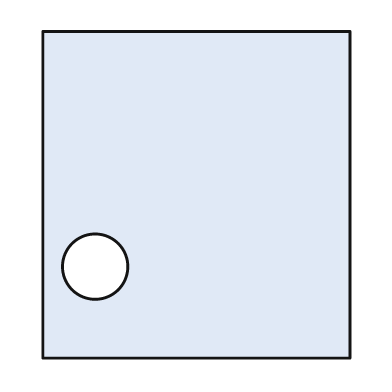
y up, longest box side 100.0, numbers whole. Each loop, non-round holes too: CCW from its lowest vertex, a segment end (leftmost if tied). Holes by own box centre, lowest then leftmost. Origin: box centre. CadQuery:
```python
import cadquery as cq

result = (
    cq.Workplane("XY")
    .moveTo(-47.0, -50.0)
    .lineTo(47.0, -50.0)
    .lineTo(47.0, 50.0)
    .lineTo(-47.0, 50.0)
    .close()
    .moveTo(-31.0, -22.0)
    .circle(10.0)
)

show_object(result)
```